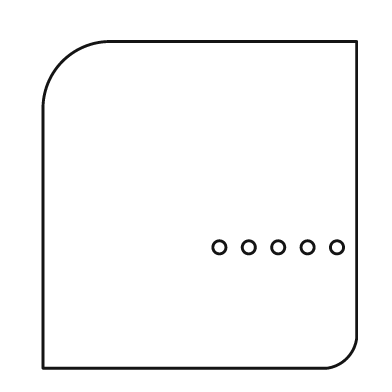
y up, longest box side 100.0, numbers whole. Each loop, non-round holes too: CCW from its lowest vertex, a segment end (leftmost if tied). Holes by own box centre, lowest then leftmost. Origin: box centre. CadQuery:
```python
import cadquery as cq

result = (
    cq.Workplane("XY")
    .moveTo(-48.0, -50.0)
    .lineTo(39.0, -50.0)
    .threePointArc((45.0, -47.0), (48.0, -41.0))
    .lineTo(48.0, 50.0)
    .lineTo(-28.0, 50.0)
    .threePointArc((-42.0, 44.0), (-48.0, 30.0))
    .close()
    .moveTo(6.0, -13.0)
    .circle(2.0)
    .moveTo(15.0, -13.0)
    .circle(2.0)
    .moveTo(24.0, -13.0)
    .circle(2.0)
    .moveTo(33.0, -13.0)
    .circle(2.0)
    .moveTo(42.0, -13.0)
    .circle(2.0)
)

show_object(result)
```